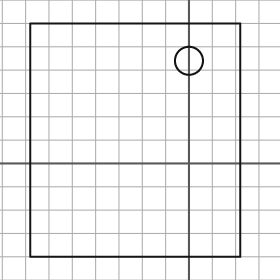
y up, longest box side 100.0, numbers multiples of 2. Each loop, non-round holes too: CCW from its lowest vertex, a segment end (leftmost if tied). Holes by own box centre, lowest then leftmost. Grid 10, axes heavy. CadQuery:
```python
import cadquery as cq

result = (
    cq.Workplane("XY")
    .moveTo(-68.0, -40.0)
    .lineTo(22.0, -40.0)
    .lineTo(22.0, 60.0)
    .lineTo(-68.0, 60.0)
    .close()
    .moveTo(0.0, 44.0)
    .circle(6.0)
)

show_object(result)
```